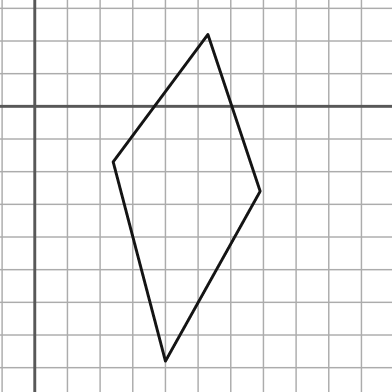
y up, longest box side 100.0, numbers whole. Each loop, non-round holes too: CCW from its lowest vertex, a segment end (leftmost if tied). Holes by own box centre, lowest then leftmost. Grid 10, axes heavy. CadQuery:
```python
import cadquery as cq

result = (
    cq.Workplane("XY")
    .moveTo(40.0, -78.0)
    .lineTo(69.0, -26.0)
    .lineTo(53.0, 22.0)
    .lineTo(24.0, -17.0)
    .close()
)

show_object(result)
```